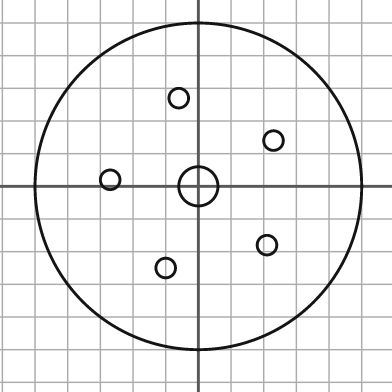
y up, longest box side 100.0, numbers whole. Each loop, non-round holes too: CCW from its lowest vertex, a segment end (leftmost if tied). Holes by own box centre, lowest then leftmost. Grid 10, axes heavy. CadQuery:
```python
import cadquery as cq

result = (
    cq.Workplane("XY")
    .moveTo(0.0, 0.0)
    .circle(50.0)
    .moveTo(-10.0, -25.0)
    .circle(3.0)
    .moveTo(21.0, -18.0)
    .circle(3.0)
    .moveTo(0.0, 0.0)
    .circle(6.0)
    .moveTo(-27.0, 2.0)
    .circle(3.0)
    .moveTo(23.0, 14.0)
    .circle(3.0)
    .moveTo(-6.0, 27.0)
    .circle(3.0)
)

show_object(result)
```